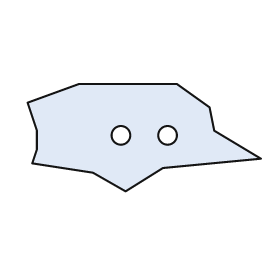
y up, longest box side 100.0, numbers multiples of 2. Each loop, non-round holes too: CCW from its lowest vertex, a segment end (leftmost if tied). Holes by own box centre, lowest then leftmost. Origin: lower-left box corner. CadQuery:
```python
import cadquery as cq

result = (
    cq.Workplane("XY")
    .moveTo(42.0, 0.0)
    .lineTo(58.0, 10.0)
    .lineTo(100.0, 14.0)
    .lineTo(80.0, 26.0)
    .lineTo(78.0, 36.0)
    .lineTo(64.0, 46.0)
    .lineTo(22.0, 46.0)
    .lineTo(0.0, 38.0)
    .lineTo(4.0, 26.0)
    .lineTo(4.0, 18.0)
    .lineTo(2.0, 12.0)
    .lineTo(28.0, 8.0)
    .close()
    .moveTo(40.0, 24.0)
    .circle(4.0)
    .moveTo(60.0, 24.0)
    .circle(4.0)
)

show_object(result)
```